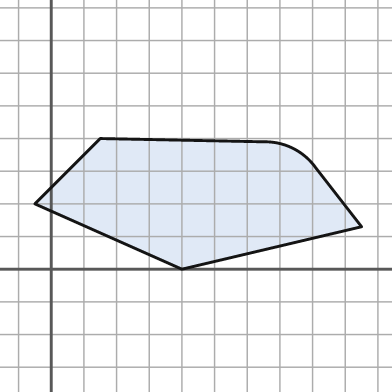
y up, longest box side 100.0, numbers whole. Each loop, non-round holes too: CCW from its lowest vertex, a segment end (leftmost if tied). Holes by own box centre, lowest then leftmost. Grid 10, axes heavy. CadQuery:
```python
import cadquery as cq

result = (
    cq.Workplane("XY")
    .moveTo(40.0, 0.0)
    .lineTo(95.0, 13.0)
    .lineTo(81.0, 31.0)
    .threePointArc((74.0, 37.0), (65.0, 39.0))
    .lineTo(15.0, 40.0)
    .lineTo(-5.0, 20.0)
    .close()
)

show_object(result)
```